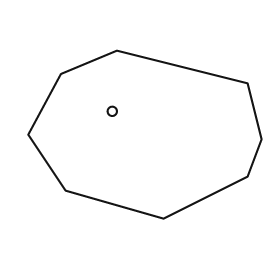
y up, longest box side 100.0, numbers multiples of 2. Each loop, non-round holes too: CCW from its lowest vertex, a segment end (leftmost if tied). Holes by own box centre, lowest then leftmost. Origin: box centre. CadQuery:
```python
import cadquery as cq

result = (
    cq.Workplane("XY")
    .moveTo(8.0, -36.0)
    .lineTo(44.0, -18.0)
    .lineTo(50.0, -2.0)
    .lineTo(44.0, 22.0)
    .lineTo(-12.0, 36.0)
    .lineTo(-36.0, 26.0)
    .lineTo(-50.0, 0.0)
    .lineTo(-34.0, -24.0)
    .close()
    .moveTo(-14.0, 10.0)
    .circle(2.0)
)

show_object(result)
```